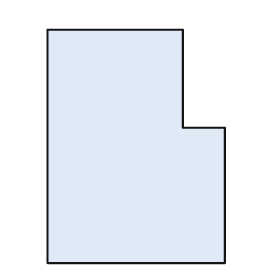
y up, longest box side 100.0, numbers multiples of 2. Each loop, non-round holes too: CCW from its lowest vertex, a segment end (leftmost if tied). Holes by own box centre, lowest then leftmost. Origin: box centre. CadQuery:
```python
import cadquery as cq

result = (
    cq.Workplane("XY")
    .moveTo(-38.0, -50.0)
    .lineTo(38.0, -50.0)
    .lineTo(38.0, 8.0)
    .lineTo(20.0, 8.0)
    .lineTo(20.0, 50.0)
    .lineTo(-38.0, 50.0)
    .close()
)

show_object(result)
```